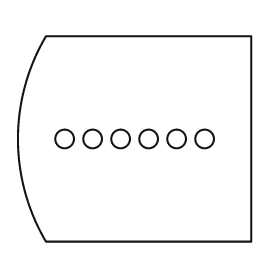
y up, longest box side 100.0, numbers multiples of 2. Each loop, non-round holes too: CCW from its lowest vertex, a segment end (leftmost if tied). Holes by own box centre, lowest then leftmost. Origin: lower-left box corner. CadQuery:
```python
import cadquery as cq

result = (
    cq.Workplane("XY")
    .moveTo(12.0, 0.0)
    .lineTo(100.0, 0.0)
    .lineTo(100.0, 88.0)
    .lineTo(12.0, 88.0)
    .threePointArc((0.0, 44.0), (12.0, 0.0))
    .close()
    .moveTo(20.0, 44.0)
    .circle(4.0)
    .moveTo(32.0, 44.0)
    .circle(4.0)
    .moveTo(44.0, 44.0)
    .circle(4.0)
    .moveTo(56.0, 44.0)
    .circle(4.0)
    .moveTo(68.0, 44.0)
    .circle(4.0)
    .moveTo(80.0, 44.0)
    .circle(4.0)
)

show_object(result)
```